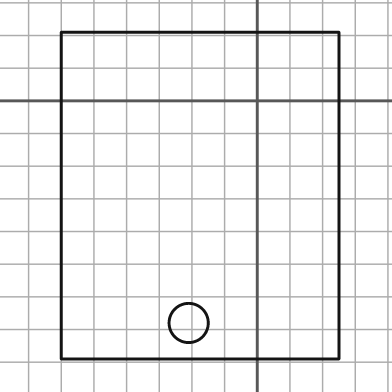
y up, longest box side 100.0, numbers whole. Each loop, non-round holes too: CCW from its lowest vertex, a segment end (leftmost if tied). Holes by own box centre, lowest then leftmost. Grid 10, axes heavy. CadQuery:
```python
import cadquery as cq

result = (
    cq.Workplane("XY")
    .moveTo(-60.0, -79.0)
    .lineTo(25.0, -79.0)
    .lineTo(25.0, 21.0)
    .lineTo(-60.0, 21.0)
    .close()
    .moveTo(-21.0, -68.0)
    .circle(6.0)
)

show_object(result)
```